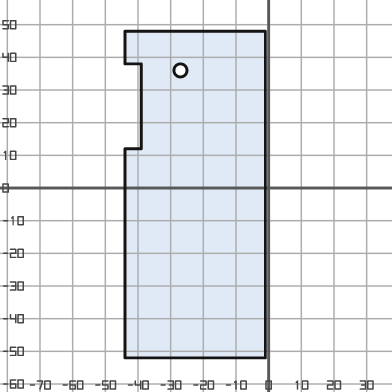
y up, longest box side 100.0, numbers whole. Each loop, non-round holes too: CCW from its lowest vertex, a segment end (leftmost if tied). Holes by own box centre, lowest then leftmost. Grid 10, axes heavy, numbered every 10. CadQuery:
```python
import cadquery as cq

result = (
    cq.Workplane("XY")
    .moveTo(-44.0, -52.0)
    .lineTo(-1.0, -52.0)
    .lineTo(-1.0, 48.0)
    .lineTo(-44.0, 48.0)
    .lineTo(-44.0, 38.0)
    .lineTo(-39.0, 38.0)
    .lineTo(-39.0, 12.0)
    .lineTo(-44.0, 12.0)
    .close()
    .moveTo(-27.0, 36.0)
    .circle(2.0)
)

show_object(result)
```